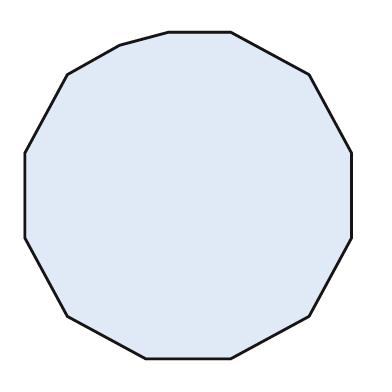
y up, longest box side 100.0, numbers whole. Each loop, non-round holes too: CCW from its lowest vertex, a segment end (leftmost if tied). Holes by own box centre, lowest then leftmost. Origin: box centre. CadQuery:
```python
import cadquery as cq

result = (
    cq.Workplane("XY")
    .moveTo(-13.0, -50.0)
    .lineTo(13.0, -50.0)
    .lineTo(37.0, -37.0)
    .lineTo(50.0, -13.0)
    .lineTo(50.0, 13.0)
    .lineTo(37.0, 37.0)
    .lineTo(13.0, 50.0)
    .lineTo(-6.0, 50.0)
    .lineTo(-21.0, 46.0)
    .lineTo(-37.0, 37.0)
    .lineTo(-50.0, 13.0)
    .lineTo(-50.0, -13.0)
    .lineTo(-37.0, -37.0)
    .close()
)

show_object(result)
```